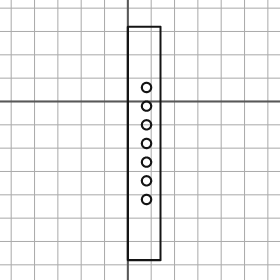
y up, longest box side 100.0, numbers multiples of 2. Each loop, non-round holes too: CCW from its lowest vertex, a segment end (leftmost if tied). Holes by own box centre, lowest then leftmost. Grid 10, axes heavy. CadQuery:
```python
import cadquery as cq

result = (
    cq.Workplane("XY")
    .moveTo(0.0, -68.0)
    .lineTo(14.0, -68.0)
    .lineTo(14.0, 32.0)
    .lineTo(0.0, 32.0)
    .close()
    .moveTo(8.0, -42.0)
    .circle(2.0)
    .moveTo(8.0, -34.0)
    .circle(2.0)
    .moveTo(8.0, -26.0)
    .circle(2.0)
    .moveTo(8.0, -18.0)
    .circle(2.0)
    .moveTo(8.0, -10.0)
    .circle(2.0)
    .moveTo(8.0, -2.0)
    .circle(2.0)
    .moveTo(8.0, 6.0)
    .circle(2.0)
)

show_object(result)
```